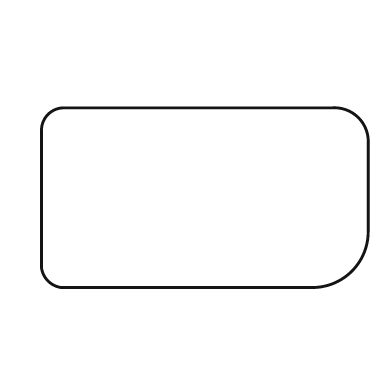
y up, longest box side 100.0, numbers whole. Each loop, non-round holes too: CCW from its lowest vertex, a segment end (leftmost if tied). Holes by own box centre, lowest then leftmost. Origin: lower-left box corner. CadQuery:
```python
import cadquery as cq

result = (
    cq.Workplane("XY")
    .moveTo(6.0, 0.0)
    .lineTo(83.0, 0.0)
    .threePointArc((95.0, 5.0), (100.0, 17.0))
    .lineTo(100.0, 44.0)
    .threePointArc((97.0, 52.0), (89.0, 55.0))
    .lineTo(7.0, 55.0)
    .threePointArc((2.0, 53.0), (0.0, 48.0))
    .lineTo(0.0, 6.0)
    .threePointArc((2.0, 2.0), (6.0, 0.0))
    .close()
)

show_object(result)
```